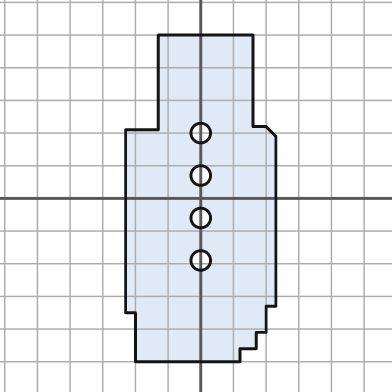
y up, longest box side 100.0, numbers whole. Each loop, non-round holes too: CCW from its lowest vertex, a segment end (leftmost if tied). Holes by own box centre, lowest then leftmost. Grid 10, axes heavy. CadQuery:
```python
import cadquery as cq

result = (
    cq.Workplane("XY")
    .moveTo(-20.0, -50.0)
    .lineTo(12.0, -50.0)
    .lineTo(12.0, -46.0)
    .lineTo(17.0, -46.0)
    .lineTo(17.0, -41.0)
    .lineTo(20.0, -41.0)
    .lineTo(20.0, -33.0)
    .lineTo(23.0, -33.0)
    .lineTo(23.0, 19.0)
    .lineTo(20.0, 22.0)
    .lineTo(16.0, 22.0)
    .lineTo(16.0, 50.0)
    .lineTo(-13.0, 50.0)
    .lineTo(-13.0, 21.0)
    .lineTo(-23.0, 21.0)
    .lineTo(-23.0, -35.0)
    .lineTo(-20.0, -35.0)
    .close()
    .moveTo(0.0, -19.0)
    .circle(3.0)
    .moveTo(0.0, -6.0)
    .circle(3.0)
    .moveTo(0.0, 7.0)
    .circle(3.0)
    .moveTo(0.0, 20.0)
    .circle(3.0)
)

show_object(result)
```